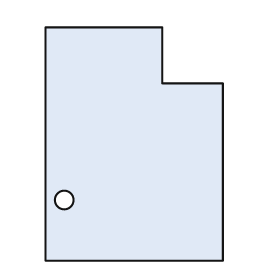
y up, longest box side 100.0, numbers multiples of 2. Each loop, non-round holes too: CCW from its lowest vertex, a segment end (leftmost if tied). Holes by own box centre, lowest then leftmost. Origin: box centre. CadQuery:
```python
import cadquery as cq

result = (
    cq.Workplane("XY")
    .moveTo(-38.0, -50.0)
    .lineTo(38.0, -50.0)
    .lineTo(38.0, 26.0)
    .lineTo(12.0, 26.0)
    .lineTo(12.0, 50.0)
    .lineTo(-38.0, 50.0)
    .close()
    .moveTo(-30.0, -24.0)
    .circle(4.0)
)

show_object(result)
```